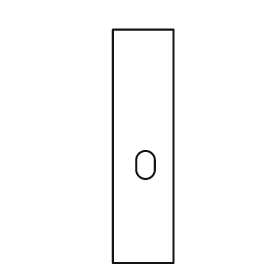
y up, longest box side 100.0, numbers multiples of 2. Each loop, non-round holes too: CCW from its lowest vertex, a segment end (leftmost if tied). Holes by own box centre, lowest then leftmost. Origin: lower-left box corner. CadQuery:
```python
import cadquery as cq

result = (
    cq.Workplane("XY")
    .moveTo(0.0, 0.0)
    .lineTo(26.0, 0.0)
    .lineTo(26.0, 100.0)
    .lineTo(0.0, 100.0)
    .close()
    .moveTo(10.0, 40.0)
    .threePointArc((14.0, 36.0), (18.0, 40.0))
    .lineTo(18.0, 44.0)
    .threePointArc((14.0, 48.0), (10.0, 44.0))
    .close()
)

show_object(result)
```